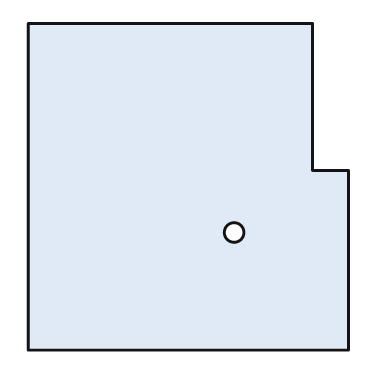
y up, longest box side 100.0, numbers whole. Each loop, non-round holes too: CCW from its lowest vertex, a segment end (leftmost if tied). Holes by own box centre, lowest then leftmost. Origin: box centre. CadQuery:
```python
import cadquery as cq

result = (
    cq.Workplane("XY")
    .moveTo(-49.0, -50.0)
    .lineTo(49.0, -50.0)
    .lineTo(49.0, 5.0)
    .lineTo(38.0, 5.0)
    .lineTo(38.0, 50.0)
    .lineTo(-49.0, 50.0)
    .close()
    .moveTo(14.0, -14.0)
    .circle(3.0)
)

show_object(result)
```